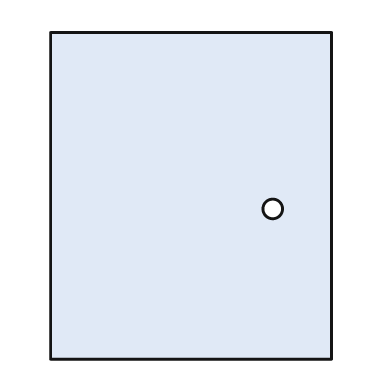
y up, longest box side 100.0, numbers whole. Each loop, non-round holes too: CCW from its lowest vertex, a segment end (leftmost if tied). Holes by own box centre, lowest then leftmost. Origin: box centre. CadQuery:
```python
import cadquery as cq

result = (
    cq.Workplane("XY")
    .moveTo(-43.0, -50.0)
    .lineTo(43.0, -50.0)
    .lineTo(43.0, 50.0)
    .lineTo(-43.0, 50.0)
    .close()
    .moveTo(25.0, -4.0)
    .circle(3.0)
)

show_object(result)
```